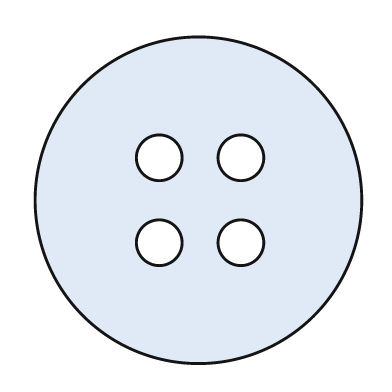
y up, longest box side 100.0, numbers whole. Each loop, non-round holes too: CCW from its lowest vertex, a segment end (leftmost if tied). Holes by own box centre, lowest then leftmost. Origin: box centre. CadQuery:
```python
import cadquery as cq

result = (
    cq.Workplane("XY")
    .moveTo(0.0, 0.0)
    .circle(50.0)
    .moveTo(-12.0, -13.0)
    .circle(7.0)
    .moveTo(13.0, -13.0)
    .circle(7.0)
    .moveTo(-12.0, 13.0)
    .circle(7.0)
    .moveTo(13.0, 13.0)
    .circle(7.0)
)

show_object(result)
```